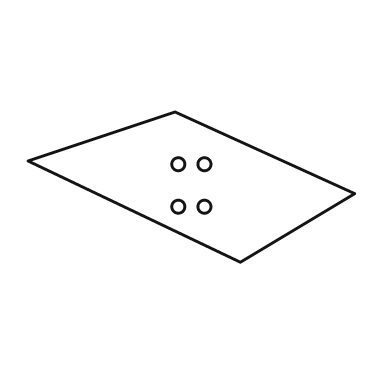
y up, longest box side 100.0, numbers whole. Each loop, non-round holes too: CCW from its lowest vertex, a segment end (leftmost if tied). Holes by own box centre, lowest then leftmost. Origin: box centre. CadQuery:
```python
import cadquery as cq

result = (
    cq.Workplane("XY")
    .moveTo(15.0, -23.0)
    .lineTo(50.0, -2.0)
    .lineTo(-5.0, 23.0)
    .lineTo(-50.0, 8.0)
    .close()
    .moveTo(-4.0, -6.0)
    .circle(2.0)
    .moveTo(4.0, -6.0)
    .circle(2.0)
    .moveTo(-4.0, 7.0)
    .circle(2.0)
    .moveTo(4.0, 7.0)
    .circle(2.0)
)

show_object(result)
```